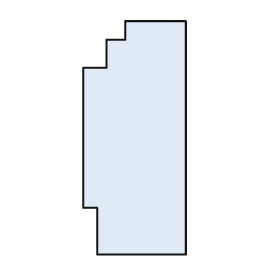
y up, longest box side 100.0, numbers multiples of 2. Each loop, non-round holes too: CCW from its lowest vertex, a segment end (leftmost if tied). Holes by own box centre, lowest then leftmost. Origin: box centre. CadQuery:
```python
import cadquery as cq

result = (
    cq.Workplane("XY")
    .moveTo(-16.0, -50.0)
    .lineTo(22.0, -50.0)
    .lineTo(22.0, 50.0)
    .lineTo(-4.0, 50.0)
    .lineTo(-4.0, 42.0)
    .lineTo(-12.0, 42.0)
    .lineTo(-12.0, 30.0)
    .lineTo(-22.0, 30.0)
    .lineTo(-22.0, -30.0)
    .lineTo(-16.0, -30.0)
    .close()
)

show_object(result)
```